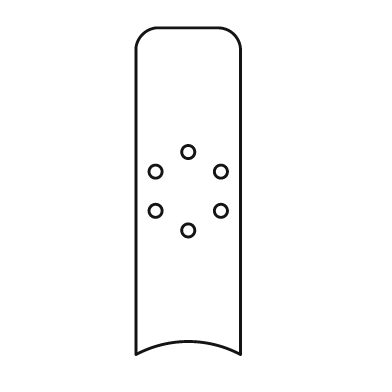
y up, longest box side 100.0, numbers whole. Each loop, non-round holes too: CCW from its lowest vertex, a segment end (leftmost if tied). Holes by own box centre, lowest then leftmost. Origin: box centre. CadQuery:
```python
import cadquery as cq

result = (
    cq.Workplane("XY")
    .moveTo(-16.0, -50.0)
    .threePointArc((0.0, -46.0), (16.0, -50.0))
    .lineTo(16.0, 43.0)
    .threePointArc((14.0, 48.0), (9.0, 50.0))
    .lineTo(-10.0, 50.0)
    .threePointArc((-14.0, 48.0), (-16.0, 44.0))
    .close()
    .moveTo(0.0, -12.0)
    .circle(2.0)
    .moveTo(-10.0, -6.0)
    .circle(2.0)
    .moveTo(10.0, -6.0)
    .circle(2.0)
    .moveTo(-10.0, 6.0)
    .circle(2.0)
    .moveTo(10.0, 6.0)
    .circle(2.0)
    .moveTo(0.0, 12.0)
    .circle(2.0)
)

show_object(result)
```